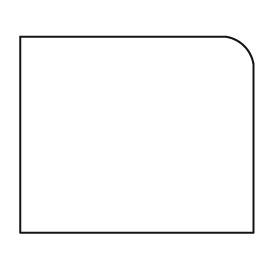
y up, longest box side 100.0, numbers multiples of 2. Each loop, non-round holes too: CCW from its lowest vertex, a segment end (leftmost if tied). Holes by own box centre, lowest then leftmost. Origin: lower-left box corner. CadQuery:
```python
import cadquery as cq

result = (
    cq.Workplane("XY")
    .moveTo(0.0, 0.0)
    .lineTo(100.0, 0.0)
    .lineTo(100.0, 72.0)
    .threePointArc((96.0, 80.0), (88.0, 84.0))
    .lineTo(0.0, 84.0)
    .close()
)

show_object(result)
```